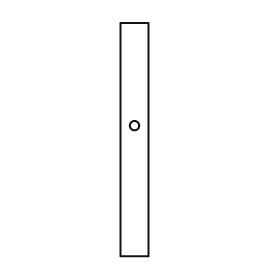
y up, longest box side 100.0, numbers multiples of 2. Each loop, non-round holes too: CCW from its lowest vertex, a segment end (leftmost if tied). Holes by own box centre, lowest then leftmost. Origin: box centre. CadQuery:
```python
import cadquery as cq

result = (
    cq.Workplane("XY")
    .moveTo(-6.0, -50.0)
    .lineTo(6.0, -50.0)
    .lineTo(6.0, 50.0)
    .lineTo(-6.0, 50.0)
    .close()
    .moveTo(0.0, 6.0)
    .circle(2.0)
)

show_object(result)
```